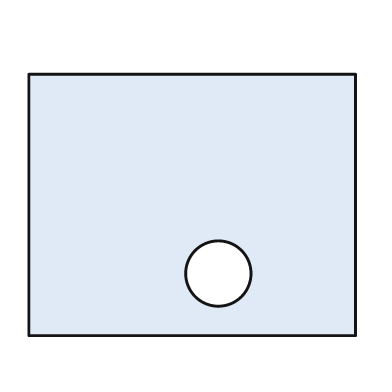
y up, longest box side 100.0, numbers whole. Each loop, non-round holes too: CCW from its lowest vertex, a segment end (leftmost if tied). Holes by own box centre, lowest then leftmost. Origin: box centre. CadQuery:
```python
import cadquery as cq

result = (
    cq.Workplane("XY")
    .moveTo(-50.0, -40.0)
    .lineTo(50.0, -40.0)
    .lineTo(50.0, 40.0)
    .lineTo(-50.0, 40.0)
    .close()
    .moveTo(8.0, -21.0)
    .circle(10.0)
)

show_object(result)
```